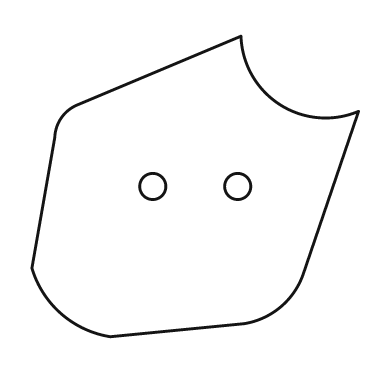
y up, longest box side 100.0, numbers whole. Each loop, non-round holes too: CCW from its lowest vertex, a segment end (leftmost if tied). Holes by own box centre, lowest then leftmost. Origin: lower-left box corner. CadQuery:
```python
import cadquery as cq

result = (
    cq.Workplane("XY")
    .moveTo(24.0, 0.0)
    .lineTo(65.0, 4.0)
    .threePointArc((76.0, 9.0), (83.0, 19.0))
    .lineTo(100.0, 69.0)
    .threePointArc((76.0, 71.0), (64.0, 92.0))
    .lineTo(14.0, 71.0)
    .threePointArc((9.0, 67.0), (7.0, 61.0))
    .lineTo(0.0, 21.0)
    .threePointArc((9.0, 7.0), (24.0, 0.0))
    .close()
    .moveTo(37.0, 46.0)
    .circle(4.0)
    .moveTo(63.0, 46.0)
    .circle(4.0)
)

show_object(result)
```